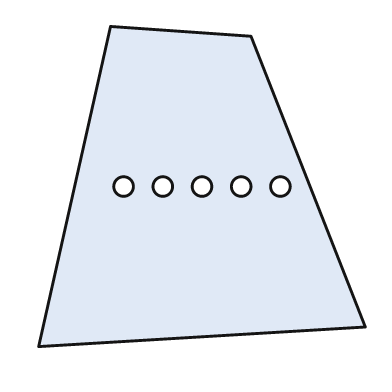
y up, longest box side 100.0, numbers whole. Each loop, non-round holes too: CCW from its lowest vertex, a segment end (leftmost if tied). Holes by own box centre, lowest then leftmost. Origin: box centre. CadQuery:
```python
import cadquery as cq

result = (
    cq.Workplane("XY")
    .moveTo(-50.0, -49.0)
    .lineTo(50.0, -43.0)
    .lineTo(15.0, 46.0)
    .lineTo(-28.0, 49.0)
    .close()
    .moveTo(-24.0, 0.0)
    .circle(3.0)
    .moveTo(-12.0, 0.0)
    .circle(3.0)
    .moveTo(0.0, 0.0)
    .circle(3.0)
    .moveTo(12.0, 0.0)
    .circle(3.0)
    .moveTo(24.0, 0.0)
    .circle(3.0)
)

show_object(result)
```